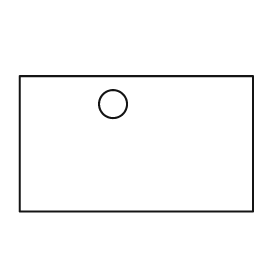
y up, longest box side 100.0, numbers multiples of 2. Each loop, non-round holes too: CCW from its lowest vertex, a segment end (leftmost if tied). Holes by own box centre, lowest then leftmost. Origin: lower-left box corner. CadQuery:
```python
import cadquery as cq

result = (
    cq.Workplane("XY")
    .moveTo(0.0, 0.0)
    .lineTo(100.0, 0.0)
    .lineTo(100.0, 58.0)
    .lineTo(0.0, 58.0)
    .close()
    .moveTo(40.0, 46.0)
    .circle(6.0)
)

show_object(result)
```